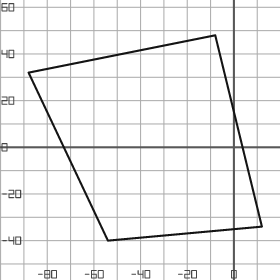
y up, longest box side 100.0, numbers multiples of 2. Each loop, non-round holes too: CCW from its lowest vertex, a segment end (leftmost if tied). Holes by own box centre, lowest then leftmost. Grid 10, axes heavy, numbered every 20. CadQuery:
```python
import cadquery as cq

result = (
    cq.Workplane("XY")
    .moveTo(-54.0, -40.0)
    .lineTo(12.0, -34.0)
    .lineTo(-8.0, 48.0)
    .lineTo(-88.0, 32.0)
    .close()
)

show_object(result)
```